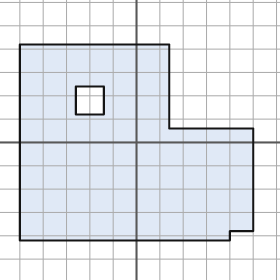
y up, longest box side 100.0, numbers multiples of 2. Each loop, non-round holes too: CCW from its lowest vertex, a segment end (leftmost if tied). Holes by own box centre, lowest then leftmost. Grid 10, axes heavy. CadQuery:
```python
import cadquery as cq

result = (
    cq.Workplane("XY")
    .moveTo(-50.0, -42.0)
    .lineTo(40.0, -42.0)
    .lineTo(40.0, -38.0)
    .lineTo(50.0, -38.0)
    .lineTo(50.0, 6.0)
    .lineTo(14.0, 6.0)
    .lineTo(14.0, 42.0)
    .lineTo(-50.0, 42.0)
    .close()
    .moveTo(-26.0, 12.0)
    .lineTo(-14.0, 12.0)
    .lineTo(-14.0, 24.0)
    .lineTo(-26.0, 24.0)
    .close()
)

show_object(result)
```